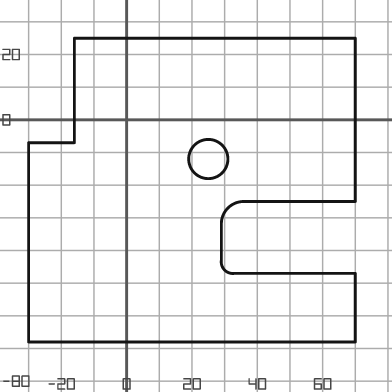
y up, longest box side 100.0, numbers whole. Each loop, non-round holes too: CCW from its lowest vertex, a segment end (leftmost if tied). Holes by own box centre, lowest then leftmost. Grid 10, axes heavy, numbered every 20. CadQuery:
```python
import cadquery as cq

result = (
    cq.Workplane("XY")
    .moveTo(-30.0, -68.0)
    .lineTo(70.0, -68.0)
    .lineTo(70.0, -47.0)
    .lineTo(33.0, -47.0)
    .threePointArc((30.0, -46.0), (29.0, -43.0))
    .lineTo(29.0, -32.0)
    .threePointArc((31.0, -27.0), (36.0, -25.0))
    .lineTo(70.0, -25.0)
    .lineTo(70.0, 25.0)
    .lineTo(-16.0, 25.0)
    .lineTo(-16.0, -7.0)
    .lineTo(-30.0, -7.0)
    .close()
    .moveTo(25.0, -12.0)
    .circle(6.0)
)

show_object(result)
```